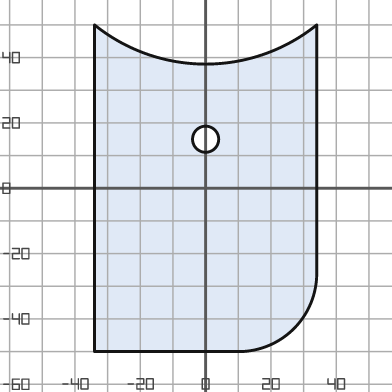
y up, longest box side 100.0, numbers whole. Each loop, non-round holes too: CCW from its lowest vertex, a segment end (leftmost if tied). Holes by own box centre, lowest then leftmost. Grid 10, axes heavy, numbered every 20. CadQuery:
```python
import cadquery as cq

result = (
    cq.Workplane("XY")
    .moveTo(-34.0, -50.0)
    .lineTo(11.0, -50.0)
    .threePointArc((27.0, -43.0), (34.0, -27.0))
    .lineTo(34.0, 50.0)
    .threePointArc((0.0, 38.0), (-34.0, 50.0))
    .close()
    .moveTo(0.0, 15.0)
    .circle(4.0)
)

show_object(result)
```